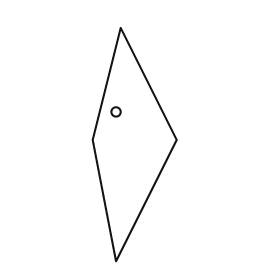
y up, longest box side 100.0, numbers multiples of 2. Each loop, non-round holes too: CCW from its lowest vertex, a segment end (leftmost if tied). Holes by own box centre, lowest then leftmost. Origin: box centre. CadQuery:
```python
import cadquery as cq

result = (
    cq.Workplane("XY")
    .moveTo(-8.0, -50.0)
    .lineTo(18.0, 2.0)
    .lineTo(-6.0, 50.0)
    .lineTo(-18.0, 2.0)
    .close()
    .moveTo(-8.0, 14.0)
    .circle(2.0)
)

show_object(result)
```